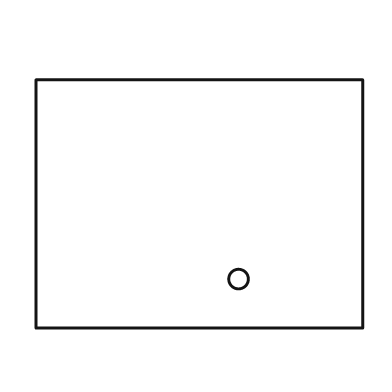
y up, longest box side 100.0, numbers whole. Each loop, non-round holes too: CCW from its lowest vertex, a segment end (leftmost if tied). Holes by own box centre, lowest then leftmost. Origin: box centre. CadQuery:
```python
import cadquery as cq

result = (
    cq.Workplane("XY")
    .moveTo(-50.0, -38.0)
    .lineTo(50.0, -38.0)
    .lineTo(50.0, 38.0)
    .lineTo(-50.0, 38.0)
    .close()
    .moveTo(12.0, -23.0)
    .circle(3.0)
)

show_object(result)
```